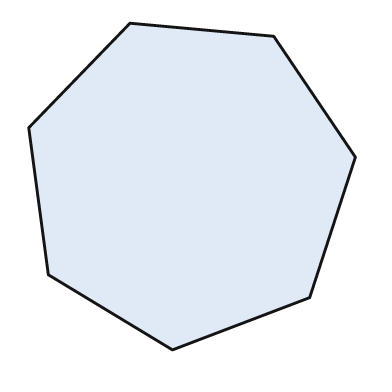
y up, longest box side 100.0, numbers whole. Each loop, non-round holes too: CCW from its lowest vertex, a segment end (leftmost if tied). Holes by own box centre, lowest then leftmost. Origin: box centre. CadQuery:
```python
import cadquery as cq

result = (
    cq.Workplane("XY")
    .moveTo(-6.0, -50.0)
    .lineTo(36.0, -34.0)
    .lineTo(50.0, 9.0)
    .lineTo(25.0, 46.0)
    .lineTo(-19.0, 50.0)
    .lineTo(-50.0, 18.0)
    .lineTo(-44.0, -27.0)
    .close()
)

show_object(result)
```